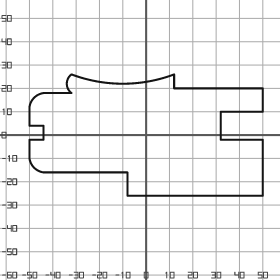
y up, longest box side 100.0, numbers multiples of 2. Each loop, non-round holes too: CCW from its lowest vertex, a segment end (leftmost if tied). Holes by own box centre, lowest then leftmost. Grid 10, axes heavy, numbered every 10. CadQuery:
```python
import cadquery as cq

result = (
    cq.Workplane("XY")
    .moveTo(-8.0, -26.0)
    .lineTo(50.0, -26.0)
    .lineTo(50.0, -2.0)
    .lineTo(32.0, -2.0)
    .lineTo(32.0, 10.0)
    .lineTo(50.0, 10.0)
    .lineTo(50.0, 20.0)
    .lineTo(12.0, 20.0)
    .lineTo(12.0, 26.0)
    .threePointArc((-10.0, 22.0), (-32.0, 26.0))
    .threePointArc((-34.0, 22.0), (-32.0, 18.0))
    .lineTo(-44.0, 18.0)
    .threePointArc((-48.0, 16.0), (-50.0, 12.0))
    .lineTo(-50.0, 4.0)
    .lineTo(-44.0, 4.0)
    .lineTo(-44.0, -2.0)
    .lineTo(-50.0, -2.0)
    .lineTo(-50.0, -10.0)
    .threePointArc((-48.0, -14.0), (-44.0, -16.0))
    .lineTo(-8.0, -16.0)
    .close()
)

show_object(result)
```